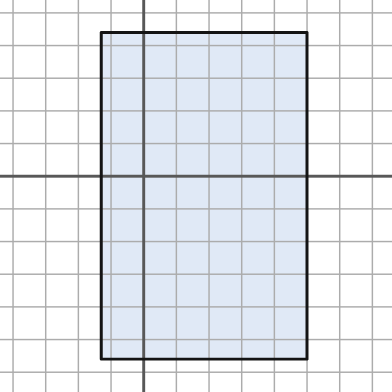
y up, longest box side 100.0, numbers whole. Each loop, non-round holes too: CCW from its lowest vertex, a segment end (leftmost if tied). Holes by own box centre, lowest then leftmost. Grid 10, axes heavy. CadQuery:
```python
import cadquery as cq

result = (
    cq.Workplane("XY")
    .moveTo(-13.0, -56.0)
    .lineTo(50.0, -56.0)
    .lineTo(50.0, 44.0)
    .lineTo(-13.0, 44.0)
    .close()
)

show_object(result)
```